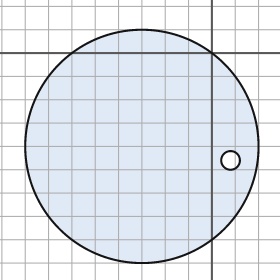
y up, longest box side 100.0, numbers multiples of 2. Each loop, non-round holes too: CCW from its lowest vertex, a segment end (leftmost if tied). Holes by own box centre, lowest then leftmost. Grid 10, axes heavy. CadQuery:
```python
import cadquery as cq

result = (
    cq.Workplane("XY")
    .moveTo(-30.0, -40.0)
    .circle(50.0)
    .moveTo(8.0, -46.0)
    .circle(4.0)
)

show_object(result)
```